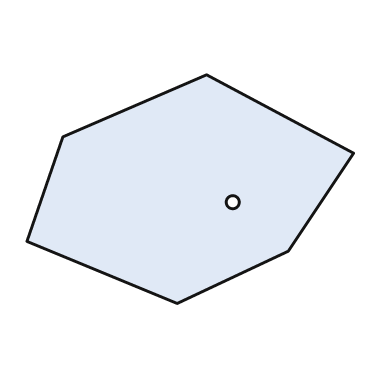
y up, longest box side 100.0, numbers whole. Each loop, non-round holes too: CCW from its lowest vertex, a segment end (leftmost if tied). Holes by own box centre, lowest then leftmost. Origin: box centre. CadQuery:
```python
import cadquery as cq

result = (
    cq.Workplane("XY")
    .moveTo(-4.0, -35.0)
    .lineTo(30.0, -19.0)
    .lineTo(50.0, 11.0)
    .lineTo(5.0, 35.0)
    .lineTo(-39.0, 16.0)
    .lineTo(-50.0, -16.0)
    .close()
    .moveTo(13.0, -4.0)
    .circle(2.0)
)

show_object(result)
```